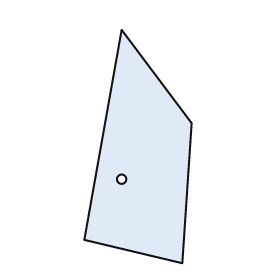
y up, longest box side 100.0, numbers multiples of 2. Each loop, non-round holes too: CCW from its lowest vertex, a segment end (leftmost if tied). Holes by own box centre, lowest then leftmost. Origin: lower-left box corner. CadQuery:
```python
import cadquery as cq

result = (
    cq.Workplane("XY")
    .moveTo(42.0, 0.0)
    .lineTo(46.0, 60.0)
    .lineTo(16.0, 100.0)
    .lineTo(0.0, 10.0)
    .close()
    .moveTo(16.0, 36.0)
    .circle(2.0)
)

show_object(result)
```